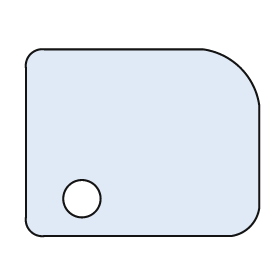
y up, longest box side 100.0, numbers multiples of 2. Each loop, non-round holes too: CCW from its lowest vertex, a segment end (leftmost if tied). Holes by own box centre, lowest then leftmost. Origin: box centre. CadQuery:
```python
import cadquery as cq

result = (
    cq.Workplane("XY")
    .moveTo(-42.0, -40.0)
    .lineTo(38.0, -40.0)
    .threePointArc((46.0, -36.0), (50.0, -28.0))
    .lineTo(50.0, 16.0)
    .threePointArc((42.0, 32.0), (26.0, 40.0))
    .lineTo(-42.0, 40.0)
    .threePointArc((-48.0, 38.0), (-50.0, 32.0))
    .lineTo(-50.0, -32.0)
    .threePointArc((-48.0, -38.0), (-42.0, -40.0))
    .close()
    .moveTo(-26.0, -24.0)
    .circle(8.0)
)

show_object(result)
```